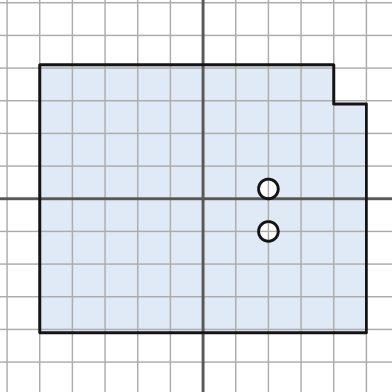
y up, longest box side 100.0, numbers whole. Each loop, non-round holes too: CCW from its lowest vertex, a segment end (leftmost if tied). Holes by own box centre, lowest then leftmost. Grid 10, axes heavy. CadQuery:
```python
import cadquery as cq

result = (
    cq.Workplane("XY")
    .moveTo(-50.0, -41.0)
    .lineTo(50.0, -41.0)
    .lineTo(50.0, 29.0)
    .lineTo(40.0, 29.0)
    .lineTo(40.0, 41.0)
    .lineTo(-50.0, 41.0)
    .close()
    .moveTo(20.0, -10.0)
    .circle(3.0)
    .moveTo(20.0, 3.0)
    .circle(3.0)
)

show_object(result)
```